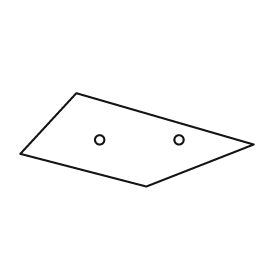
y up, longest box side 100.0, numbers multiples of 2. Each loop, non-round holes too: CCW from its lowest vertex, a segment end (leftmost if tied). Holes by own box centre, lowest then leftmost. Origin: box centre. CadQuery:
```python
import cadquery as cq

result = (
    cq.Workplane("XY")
    .moveTo(4.0, -20.0)
    .lineTo(50.0, -2.0)
    .lineTo(-26.0, 20.0)
    .lineTo(-50.0, -6.0)
    .close()
    .moveTo(-16.0, 0.0)
    .circle(2.0)
    .moveTo(18.0, 0.0)
    .circle(2.0)
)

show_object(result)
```